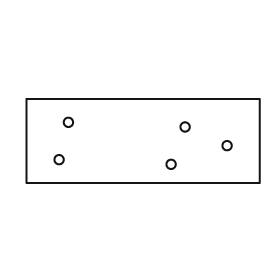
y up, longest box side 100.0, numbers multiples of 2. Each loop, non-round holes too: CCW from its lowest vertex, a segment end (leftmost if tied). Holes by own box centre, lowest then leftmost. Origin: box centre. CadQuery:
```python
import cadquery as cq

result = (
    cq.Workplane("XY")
    .moveTo(-50.0, -18.0)
    .lineTo(50.0, -18.0)
    .lineTo(50.0, 18.0)
    .lineTo(-50.0, 18.0)
    .close()
    .moveTo(12.0, -10.0)
    .circle(2.0)
    .moveTo(-36.0, -8.0)
    .circle(2.0)
    .moveTo(36.0, -2.0)
    .circle(2.0)
    .moveTo(18.0, 6.0)
    .circle(2.0)
    .moveTo(-32.0, 8.0)
    .circle(2.0)
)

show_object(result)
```